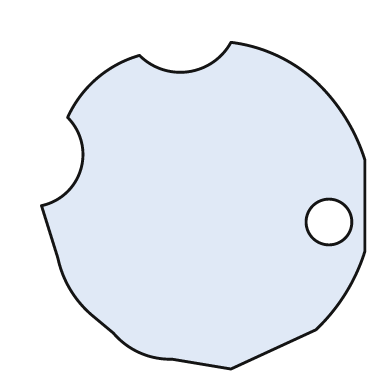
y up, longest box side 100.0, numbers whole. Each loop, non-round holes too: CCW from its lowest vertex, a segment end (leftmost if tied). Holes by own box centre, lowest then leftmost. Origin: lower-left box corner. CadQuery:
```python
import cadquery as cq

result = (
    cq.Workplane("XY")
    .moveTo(58.0, 0.0)
    .lineTo(84.0, 12.0)
    .threePointArc((93.0, 23.0), (99.0, 36.0))
    .lineTo(99.0, 64.0)
    .threePointArc((93.0, 77.0), (84.0, 88.0))
    .threePointArc((72.0, 96.0), (58.0, 100.0))
    .threePointArc((45.0, 91.0), (30.0, 96.0))
    .threePointArc((17.0, 89.0), (8.0, 77.0))
    .threePointArc((12.0, 61.0), (0.0, 50.0))
    .lineTo(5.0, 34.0)
    .threePointArc((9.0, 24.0), (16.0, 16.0))
    .lineTo(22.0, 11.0)
    .threePointArc((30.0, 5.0), (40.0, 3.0))
    .close()
    .moveTo(88.0, 45.0)
    .circle(7.0)
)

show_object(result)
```